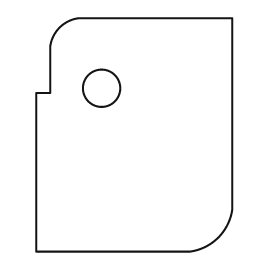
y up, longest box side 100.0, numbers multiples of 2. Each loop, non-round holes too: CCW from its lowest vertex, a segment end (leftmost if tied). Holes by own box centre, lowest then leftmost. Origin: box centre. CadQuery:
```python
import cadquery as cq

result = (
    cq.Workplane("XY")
    .moveTo(-42.0, -50.0)
    .lineTo(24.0, -50.0)
    .threePointArc((36.0, -44.0), (42.0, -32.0))
    .lineTo(42.0, 50.0)
    .lineTo(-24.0, 50.0)
    .threePointArc((-32.0, 46.0), (-36.0, 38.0))
    .lineTo(-36.0, 18.0)
    .lineTo(-42.0, 18.0)
    .close()
    .moveTo(-14.0, 20.0)
    .circle(8.0)
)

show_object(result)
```